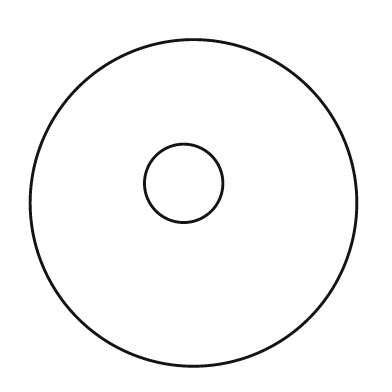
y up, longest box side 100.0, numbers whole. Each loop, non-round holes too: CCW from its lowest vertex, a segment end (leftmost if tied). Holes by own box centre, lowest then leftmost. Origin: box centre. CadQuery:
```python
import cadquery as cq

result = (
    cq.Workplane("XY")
    .moveTo(0.0, 0.0)
    .circle(50.0)
    .moveTo(-3.0, 6.0)
    .circle(12.0)
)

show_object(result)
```